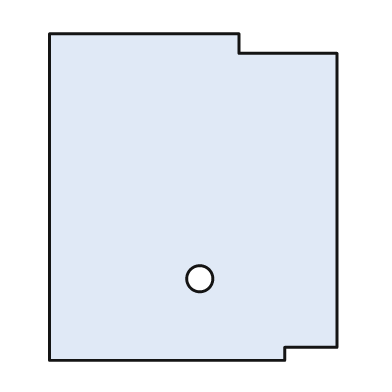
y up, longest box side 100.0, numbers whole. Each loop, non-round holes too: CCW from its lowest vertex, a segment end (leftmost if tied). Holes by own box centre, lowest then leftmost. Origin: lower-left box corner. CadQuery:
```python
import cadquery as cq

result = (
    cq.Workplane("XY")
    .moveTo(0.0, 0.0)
    .lineTo(72.0, 0.0)
    .lineTo(72.0, 4.0)
    .lineTo(88.0, 4.0)
    .lineTo(88.0, 94.0)
    .lineTo(58.0, 94.0)
    .lineTo(58.0, 100.0)
    .lineTo(0.0, 100.0)
    .close()
    .moveTo(46.0, 25.0)
    .circle(4.0)
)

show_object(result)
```